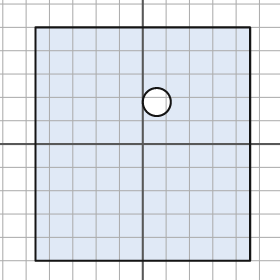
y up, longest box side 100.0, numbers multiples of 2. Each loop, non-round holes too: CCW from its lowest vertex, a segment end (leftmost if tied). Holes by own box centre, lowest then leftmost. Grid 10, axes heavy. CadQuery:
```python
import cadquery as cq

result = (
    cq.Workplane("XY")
    .moveTo(-46.0, -50.0)
    .lineTo(46.0, -50.0)
    .lineTo(46.0, 50.0)
    .lineTo(-46.0, 50.0)
    .close()
    .moveTo(6.0, 18.0)
    .circle(6.0)
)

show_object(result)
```